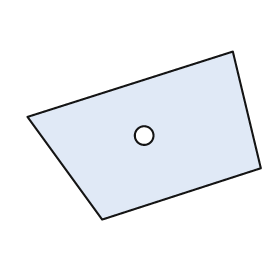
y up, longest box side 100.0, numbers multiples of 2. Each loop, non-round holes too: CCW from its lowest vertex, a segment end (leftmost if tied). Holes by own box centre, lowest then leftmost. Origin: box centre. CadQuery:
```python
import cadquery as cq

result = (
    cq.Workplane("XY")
    .moveTo(-18.0, -36.0)
    .lineTo(50.0, -14.0)
    .lineTo(38.0, 36.0)
    .lineTo(-50.0, 8.0)
    .close()
    .moveTo(0.0, 0.0)
    .circle(4.0)
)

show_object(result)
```